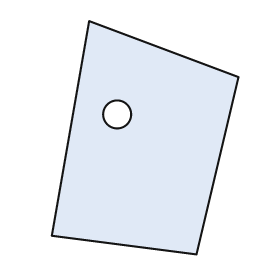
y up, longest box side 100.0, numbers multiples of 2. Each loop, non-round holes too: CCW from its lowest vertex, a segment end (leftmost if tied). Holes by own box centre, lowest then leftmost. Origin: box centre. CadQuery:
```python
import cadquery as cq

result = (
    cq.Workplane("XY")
    .moveTo(22.0, -50.0)
    .lineTo(40.0, 26.0)
    .lineTo(-24.0, 50.0)
    .lineTo(-40.0, -42.0)
    .close()
    .moveTo(-12.0, 10.0)
    .circle(6.0)
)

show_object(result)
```